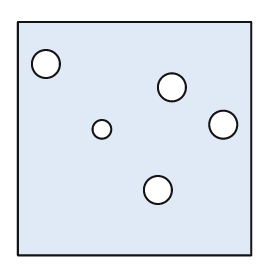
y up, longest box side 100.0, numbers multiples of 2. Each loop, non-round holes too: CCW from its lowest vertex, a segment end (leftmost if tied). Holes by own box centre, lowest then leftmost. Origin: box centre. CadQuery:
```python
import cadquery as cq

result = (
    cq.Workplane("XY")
    .moveTo(-50.0, -50.0)
    .lineTo(50.0, -50.0)
    .lineTo(50.0, 50.0)
    .lineTo(-50.0, 50.0)
    .close()
    .moveTo(10.0, -22.0)
    .circle(6.0)
    .moveTo(-14.0, 4.0)
    .circle(4.0)
    .moveTo(38.0, 6.0)
    .circle(6.0)
    .moveTo(16.0, 22.0)
    .circle(6.0)
    .moveTo(-38.0, 32.0)
    .circle(6.0)
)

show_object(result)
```